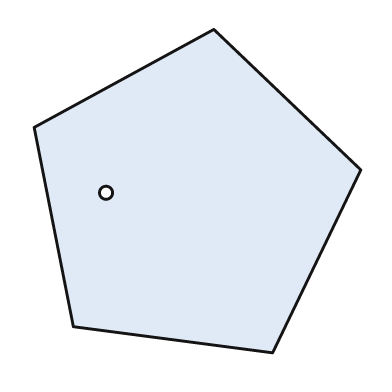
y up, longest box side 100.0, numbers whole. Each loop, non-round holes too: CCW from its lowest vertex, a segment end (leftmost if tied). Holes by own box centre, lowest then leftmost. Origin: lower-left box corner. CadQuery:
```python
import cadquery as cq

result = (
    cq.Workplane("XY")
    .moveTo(73.0, 0.0)
    .lineTo(100.0, 56.0)
    .lineTo(55.0, 99.0)
    .lineTo(0.0, 69.0)
    .lineTo(12.0, 8.0)
    .close()
    .moveTo(22.0, 49.0)
    .circle(2.0)
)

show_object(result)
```